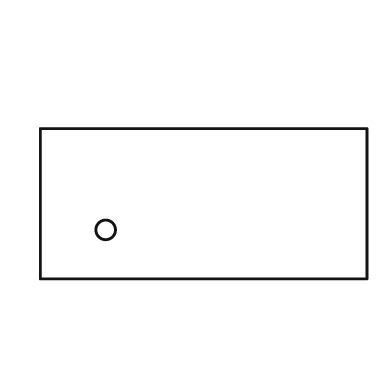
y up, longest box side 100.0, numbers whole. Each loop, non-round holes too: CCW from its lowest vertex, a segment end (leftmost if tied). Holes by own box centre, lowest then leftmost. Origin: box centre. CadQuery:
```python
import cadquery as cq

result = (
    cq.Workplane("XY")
    .moveTo(-50.0, -23.0)
    .lineTo(50.0, -23.0)
    .lineTo(50.0, 23.0)
    .lineTo(-50.0, 23.0)
    .close()
    .moveTo(-30.0, -8.0)
    .circle(3.0)
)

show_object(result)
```